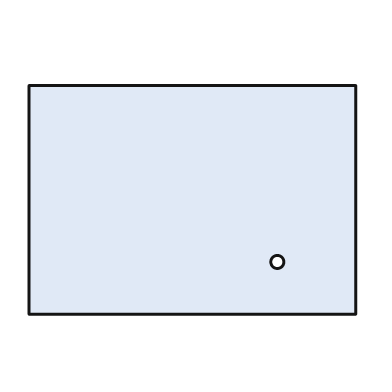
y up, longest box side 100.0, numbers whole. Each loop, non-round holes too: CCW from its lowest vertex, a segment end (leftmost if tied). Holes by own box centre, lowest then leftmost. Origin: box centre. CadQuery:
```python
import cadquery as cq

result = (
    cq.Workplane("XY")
    .moveTo(-50.0, -35.0)
    .lineTo(50.0, -35.0)
    .lineTo(50.0, 35.0)
    .lineTo(-50.0, 35.0)
    .close()
    .moveTo(26.0, -19.0)
    .circle(2.0)
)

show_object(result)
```